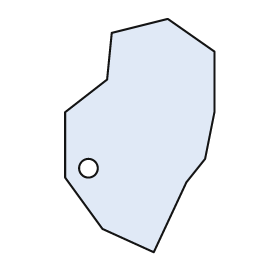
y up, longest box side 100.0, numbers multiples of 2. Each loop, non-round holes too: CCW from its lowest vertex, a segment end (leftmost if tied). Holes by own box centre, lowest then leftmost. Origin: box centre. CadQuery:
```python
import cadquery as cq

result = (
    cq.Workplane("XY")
    .moveTo(6.0, -50.0)
    .lineTo(20.0, -20.0)
    .lineTo(28.0, -10.0)
    .lineTo(32.0, 10.0)
    .lineTo(32.0, 36.0)
    .lineTo(12.0, 50.0)
    .lineTo(-12.0, 44.0)
    .lineTo(-14.0, 24.0)
    .lineTo(-32.0, 10.0)
    .lineTo(-32.0, -18.0)
    .lineTo(-16.0, -40.0)
    .close()
    .moveTo(-22.0, -14.0)
    .circle(4.0)
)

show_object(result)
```